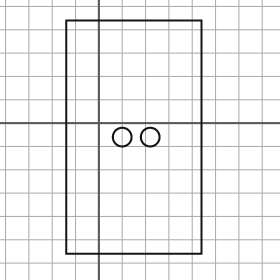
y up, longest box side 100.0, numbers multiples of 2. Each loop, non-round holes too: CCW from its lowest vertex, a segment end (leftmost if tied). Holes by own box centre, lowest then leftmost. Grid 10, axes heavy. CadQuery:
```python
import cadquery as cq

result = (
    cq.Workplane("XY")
    .moveTo(-14.0, -56.0)
    .lineTo(44.0, -56.0)
    .lineTo(44.0, 44.0)
    .lineTo(-14.0, 44.0)
    .close()
    .moveTo(10.0, -6.0)
    .circle(4.0)
    .moveTo(22.0, -6.0)
    .circle(4.0)
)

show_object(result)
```